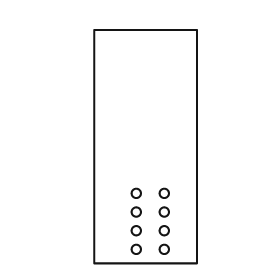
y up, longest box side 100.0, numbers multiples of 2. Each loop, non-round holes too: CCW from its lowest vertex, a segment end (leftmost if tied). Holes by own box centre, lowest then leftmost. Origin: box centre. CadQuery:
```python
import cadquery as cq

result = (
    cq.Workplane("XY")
    .moveTo(-22.0, -50.0)
    .lineTo(22.0, -50.0)
    .lineTo(22.0, 50.0)
    .lineTo(-22.0, 50.0)
    .close()
    .moveTo(-4.0, -44.0)
    .circle(2.0)
    .moveTo(8.0, -44.0)
    .circle(2.0)
    .moveTo(-4.0, -36.0)
    .circle(2.0)
    .moveTo(8.0, -36.0)
    .circle(2.0)
    .moveTo(-4.0, -28.0)
    .circle(2.0)
    .moveTo(8.0, -28.0)
    .circle(2.0)
    .moveTo(-4.0, -20.0)
    .circle(2.0)
    .moveTo(8.0, -20.0)
    .circle(2.0)
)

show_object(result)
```